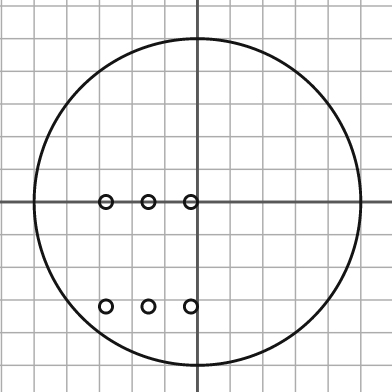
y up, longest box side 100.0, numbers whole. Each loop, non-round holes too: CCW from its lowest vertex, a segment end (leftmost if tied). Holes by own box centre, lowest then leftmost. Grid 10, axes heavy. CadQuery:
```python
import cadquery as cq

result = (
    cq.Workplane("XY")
    .moveTo(0.0, 0.0)
    .circle(50.0)
    .moveTo(-28.0, -32.0)
    .circle(2.0)
    .moveTo(-15.0, -32.0)
    .circle(2.0)
    .moveTo(-2.0, -32.0)
    .circle(2.0)
    .moveTo(-28.0, 0.0)
    .circle(2.0)
    .moveTo(-15.0, 0.0)
    .circle(2.0)
    .moveTo(-2.0, 0.0)
    .circle(2.0)
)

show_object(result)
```